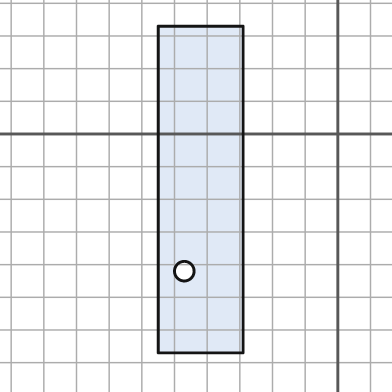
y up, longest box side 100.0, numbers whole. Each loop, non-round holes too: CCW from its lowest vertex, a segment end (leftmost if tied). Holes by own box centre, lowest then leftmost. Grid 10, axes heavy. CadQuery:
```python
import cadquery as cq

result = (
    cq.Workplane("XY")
    .moveTo(-55.0, -67.0)
    .lineTo(-29.0, -67.0)
    .lineTo(-29.0, 33.0)
    .lineTo(-55.0, 33.0)
    .close()
    .moveTo(-47.0, -42.0)
    .circle(3.0)
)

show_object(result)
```